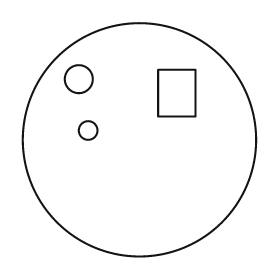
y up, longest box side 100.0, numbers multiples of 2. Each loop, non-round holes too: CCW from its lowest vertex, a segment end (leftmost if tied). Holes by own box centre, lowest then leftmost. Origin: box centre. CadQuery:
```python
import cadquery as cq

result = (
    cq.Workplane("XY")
    .moveTo(0.0, 0.0)
    .circle(50.0)
    .moveTo(-22.0, 4.0)
    .circle(4.0)
    .moveTo(8.0, 10.0)
    .lineTo(24.0, 10.0)
    .lineTo(24.0, 30.0)
    .lineTo(8.0, 30.0)
    .close()
    .moveTo(-26.0, 26.0)
    .circle(6.0)
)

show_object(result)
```